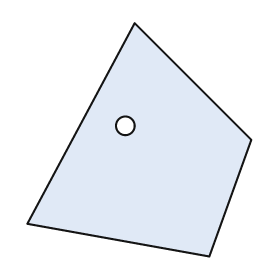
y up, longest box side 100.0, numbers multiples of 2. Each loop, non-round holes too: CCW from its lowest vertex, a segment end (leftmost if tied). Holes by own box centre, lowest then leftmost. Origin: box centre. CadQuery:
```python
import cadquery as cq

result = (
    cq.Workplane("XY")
    .moveTo(30.0, -50.0)
    .lineTo(48.0, 0.0)
    .lineTo(-2.0, 50.0)
    .lineTo(-48.0, -36.0)
    .close()
    .moveTo(-6.0, 6.0)
    .circle(4.0)
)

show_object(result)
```